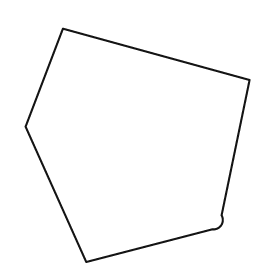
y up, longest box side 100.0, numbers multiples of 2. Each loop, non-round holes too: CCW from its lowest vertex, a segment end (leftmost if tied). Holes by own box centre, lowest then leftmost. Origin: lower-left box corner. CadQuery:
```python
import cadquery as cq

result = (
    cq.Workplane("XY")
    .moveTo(26.0, 0.0)
    .lineTo(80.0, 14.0)
    .threePointArc((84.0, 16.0), (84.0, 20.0))
    .lineTo(96.0, 78.0)
    .lineTo(16.0, 100.0)
    .lineTo(0.0, 58.0)
    .close()
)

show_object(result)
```